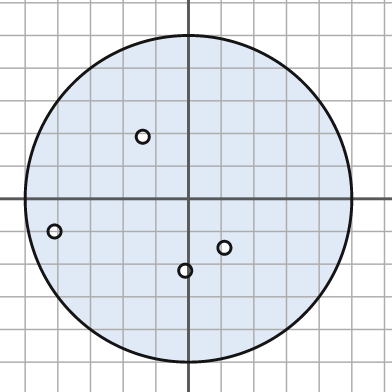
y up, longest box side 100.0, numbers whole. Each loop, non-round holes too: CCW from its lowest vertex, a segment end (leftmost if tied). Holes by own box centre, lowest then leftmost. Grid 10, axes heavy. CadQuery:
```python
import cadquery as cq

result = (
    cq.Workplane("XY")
    .moveTo(0.0, 0.0)
    .circle(50.0)
    .moveTo(-1.0, -22.0)
    .circle(2.0)
    .moveTo(11.0, -15.0)
    .circle(2.0)
    .moveTo(-41.0, -10.0)
    .circle(2.0)
    .moveTo(-14.0, 19.0)
    .circle(2.0)
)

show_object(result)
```